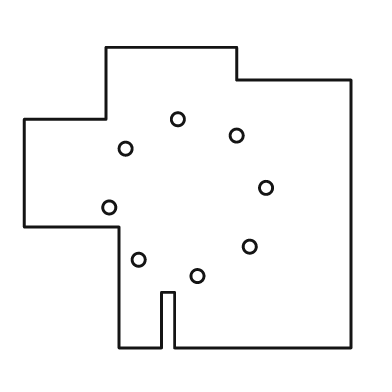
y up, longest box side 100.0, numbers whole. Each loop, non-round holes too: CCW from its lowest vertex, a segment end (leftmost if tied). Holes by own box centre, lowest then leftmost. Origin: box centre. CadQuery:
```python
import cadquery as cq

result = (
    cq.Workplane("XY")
    .moveTo(-21.0, -46.0)
    .lineTo(-8.0, -46.0)
    .lineTo(-8.0, -29.0)
    .lineTo(-4.0, -29.0)
    .lineTo(-4.0, -46.0)
    .lineTo(50.0, -46.0)
    .lineTo(50.0, 36.0)
    .lineTo(15.0, 36.0)
    .lineTo(15.0, 46.0)
    .lineTo(-25.0, 46.0)
    .lineTo(-25.0, 24.0)
    .lineTo(-50.0, 24.0)
    .lineTo(-50.0, -9.0)
    .lineTo(-21.0, -9.0)
    .close()
    .moveTo(3.0, -24.0)
    .circle(2.0)
    .moveTo(-15.0, -19.0)
    .circle(2.0)
    .moveTo(19.0, -15.0)
    .circle(2.0)
    .moveTo(-24.0, -3.0)
    .circle(2.0)
    .moveTo(24.0, 3.0)
    .circle(2.0)
    .moveTo(-19.0, 15.0)
    .circle(2.0)
    .moveTo(15.0, 19.0)
    .circle(2.0)
    .moveTo(-3.0, 24.0)
    .circle(2.0)
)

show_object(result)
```